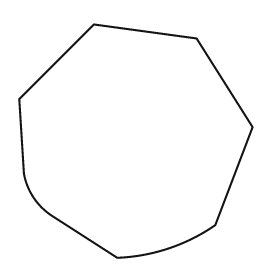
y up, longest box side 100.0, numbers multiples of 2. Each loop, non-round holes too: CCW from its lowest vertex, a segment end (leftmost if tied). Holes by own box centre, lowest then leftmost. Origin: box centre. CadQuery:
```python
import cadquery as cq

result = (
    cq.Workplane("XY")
    .moveTo(-8.0, -50.0)
    .threePointArc((14.0, -46.0), (34.0, -36.0))
    .lineTo(50.0, 6.0)
    .lineTo(26.0, 44.0)
    .lineTo(-18.0, 50.0)
    .lineTo(-50.0, 18.0)
    .lineTo(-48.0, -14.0)
    .threePointArc((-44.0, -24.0), (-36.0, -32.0))
    .close()
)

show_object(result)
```